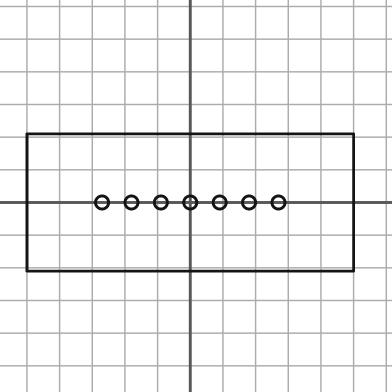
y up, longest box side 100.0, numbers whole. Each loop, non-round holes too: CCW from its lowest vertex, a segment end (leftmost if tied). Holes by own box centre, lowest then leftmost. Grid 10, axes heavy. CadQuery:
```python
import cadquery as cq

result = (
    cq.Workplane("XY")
    .moveTo(-50.0, -21.0)
    .lineTo(50.0, -21.0)
    .lineTo(50.0, 21.0)
    .lineTo(-50.0, 21.0)
    .close()
    .moveTo(-27.0, 0.0)
    .circle(2.0)
    .moveTo(-18.0, 0.0)
    .circle(2.0)
    .moveTo(-9.0, 0.0)
    .circle(2.0)
    .moveTo(0.0, 0.0)
    .circle(2.0)
    .moveTo(9.0, 0.0)
    .circle(2.0)
    .moveTo(18.0, 0.0)
    .circle(2.0)
    .moveTo(27.0, 0.0)
    .circle(2.0)
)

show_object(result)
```